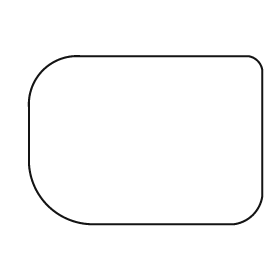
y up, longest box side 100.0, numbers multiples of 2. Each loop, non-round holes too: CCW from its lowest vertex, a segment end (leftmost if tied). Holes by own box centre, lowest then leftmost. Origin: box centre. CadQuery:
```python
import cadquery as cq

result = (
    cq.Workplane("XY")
    .moveTo(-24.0, -36.0)
    .lineTo(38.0, -36.0)
    .threePointArc((46.0, -32.0), (50.0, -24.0))
    .lineTo(50.0, 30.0)
    .threePointArc((48.0, 34.0), (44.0, 36.0))
    .lineTo(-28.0, 36.0)
    .threePointArc((-44.0, 30.0), (-50.0, 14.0))
    .lineTo(-50.0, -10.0)
    .threePointArc((-42.0, -28.0), (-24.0, -36.0))
    .close()
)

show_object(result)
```